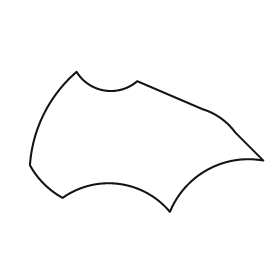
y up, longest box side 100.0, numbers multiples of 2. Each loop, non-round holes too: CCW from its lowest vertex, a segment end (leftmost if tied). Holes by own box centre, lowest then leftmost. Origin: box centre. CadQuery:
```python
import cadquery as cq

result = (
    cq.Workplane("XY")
    .moveTo(10.0, -30.0)
    .threePointArc((26.0, -12.0), (50.0, -8.0))
    .lineTo(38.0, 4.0)
    .threePointArc((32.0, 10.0), (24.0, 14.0))
    .lineTo(-4.0, 26.0)
    .threePointArc((-18.0, 22.0), (-30.0, 30.0))
    .threePointArc((-44.0, 12.0), (-50.0, -10.0))
    .threePointArc((-44.0, -18.0), (-36.0, -24.0))
    .threePointArc((-12.0, -18.0), (10.0, -30.0))
    .close()
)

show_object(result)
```